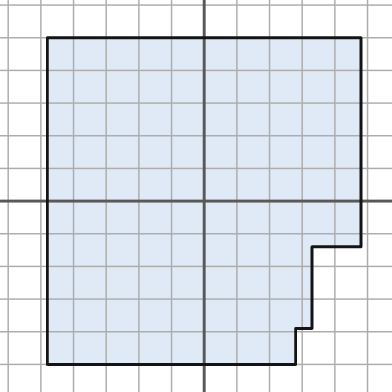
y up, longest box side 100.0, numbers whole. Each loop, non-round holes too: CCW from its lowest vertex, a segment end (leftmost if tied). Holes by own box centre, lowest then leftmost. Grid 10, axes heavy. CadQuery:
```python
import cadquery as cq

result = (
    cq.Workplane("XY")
    .moveTo(-48.0, -50.0)
    .lineTo(28.0, -50.0)
    .lineTo(28.0, -39.0)
    .lineTo(33.0, -39.0)
    .lineTo(33.0, -14.0)
    .lineTo(48.0, -14.0)
    .lineTo(48.0, 50.0)
    .lineTo(-48.0, 50.0)
    .close()
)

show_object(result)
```